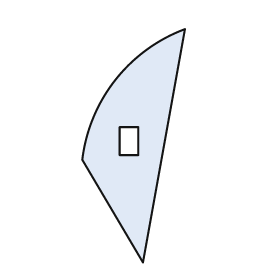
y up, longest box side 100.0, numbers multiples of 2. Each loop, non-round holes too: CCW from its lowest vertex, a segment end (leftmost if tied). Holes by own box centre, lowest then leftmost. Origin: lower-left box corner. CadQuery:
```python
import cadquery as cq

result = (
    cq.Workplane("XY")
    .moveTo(26.0, 0.0)
    .lineTo(44.0, 100.0)
    .threePointArc((14.0, 78.0), (0.0, 44.0))
    .close()
    .moveTo(16.0, 46.0)
    .lineTo(24.0, 46.0)
    .lineTo(24.0, 58.0)
    .lineTo(16.0, 58.0)
    .close()
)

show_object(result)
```